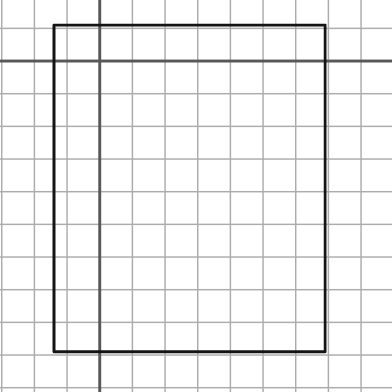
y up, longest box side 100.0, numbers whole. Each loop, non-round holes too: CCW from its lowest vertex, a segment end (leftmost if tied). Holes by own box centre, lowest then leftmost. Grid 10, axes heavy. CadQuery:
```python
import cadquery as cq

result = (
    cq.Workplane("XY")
    .moveTo(-14.0, -89.0)
    .lineTo(69.0, -89.0)
    .lineTo(69.0, 11.0)
    .lineTo(-14.0, 11.0)
    .close()
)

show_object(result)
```